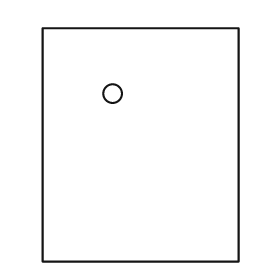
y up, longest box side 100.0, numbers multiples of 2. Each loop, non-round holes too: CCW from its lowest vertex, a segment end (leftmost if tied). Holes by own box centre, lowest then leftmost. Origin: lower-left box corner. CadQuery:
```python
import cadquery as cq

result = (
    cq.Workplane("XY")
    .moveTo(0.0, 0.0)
    .lineTo(84.0, 0.0)
    .lineTo(84.0, 100.0)
    .lineTo(0.0, 100.0)
    .close()
    .moveTo(30.0, 72.0)
    .circle(4.0)
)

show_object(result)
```